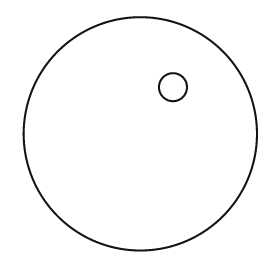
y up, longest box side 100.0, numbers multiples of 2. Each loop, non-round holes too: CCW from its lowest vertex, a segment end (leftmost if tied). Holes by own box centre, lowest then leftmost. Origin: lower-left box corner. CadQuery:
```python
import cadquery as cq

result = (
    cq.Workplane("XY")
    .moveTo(50.0, 50.0)
    .circle(50.0)
    .moveTo(64.0, 70.0)
    .circle(6.0)
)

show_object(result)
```